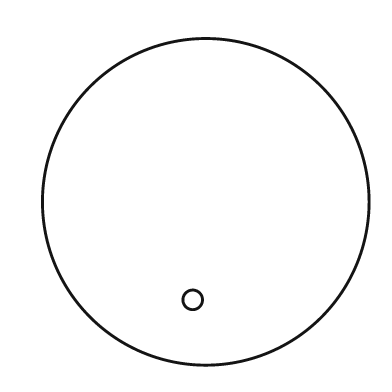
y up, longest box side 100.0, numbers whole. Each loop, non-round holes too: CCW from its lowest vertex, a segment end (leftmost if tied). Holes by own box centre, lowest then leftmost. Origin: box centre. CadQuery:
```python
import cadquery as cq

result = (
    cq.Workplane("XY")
    .moveTo(0.0, 0.0)
    .circle(50.0)
    .moveTo(-4.0, -30.0)
    .circle(3.0)
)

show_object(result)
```